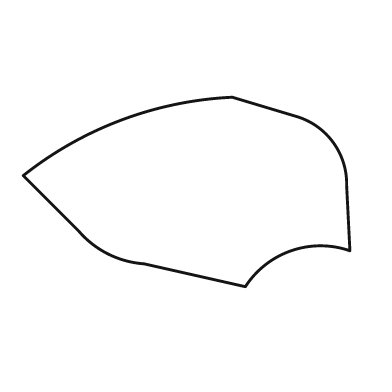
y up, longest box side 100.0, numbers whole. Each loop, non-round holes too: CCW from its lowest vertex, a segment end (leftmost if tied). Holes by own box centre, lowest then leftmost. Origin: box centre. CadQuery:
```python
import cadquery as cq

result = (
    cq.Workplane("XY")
    .moveTo(18.0, -29.0)
    .threePointArc((32.0, -18.0), (50.0, -18.0))
    .lineTo(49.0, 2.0)
    .threePointArc((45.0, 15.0), (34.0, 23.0))
    .lineTo(14.0, 29.0)
    .threePointArc((-20.0, 22.0), (-50.0, 5.0))
    .lineTo(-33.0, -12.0)
    .threePointArc((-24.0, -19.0), (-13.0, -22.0))
    .close()
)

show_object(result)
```